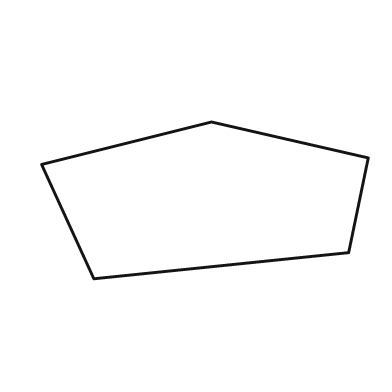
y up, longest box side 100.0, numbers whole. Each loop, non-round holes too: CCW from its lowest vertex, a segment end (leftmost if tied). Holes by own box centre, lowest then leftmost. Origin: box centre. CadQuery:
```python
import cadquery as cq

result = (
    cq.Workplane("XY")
    .moveTo(-34.0, -24.0)
    .lineTo(44.0, -16.0)
    .lineTo(50.0, 13.0)
    .lineTo(2.0, 24.0)
    .lineTo(-50.0, 11.0)
    .close()
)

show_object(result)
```